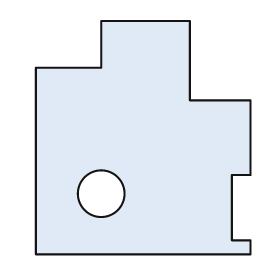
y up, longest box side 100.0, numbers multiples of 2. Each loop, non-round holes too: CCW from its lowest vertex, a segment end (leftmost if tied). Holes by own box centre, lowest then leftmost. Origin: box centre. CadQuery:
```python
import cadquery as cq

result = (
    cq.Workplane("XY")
    .moveTo(-46.0, -50.0)
    .lineTo(46.0, -50.0)
    .lineTo(46.0, -44.0)
    .lineTo(38.0, -44.0)
    .lineTo(38.0, -16.0)
    .lineTo(46.0, -16.0)
    .lineTo(46.0, 16.0)
    .lineTo(20.0, 16.0)
    .lineTo(20.0, 50.0)
    .lineTo(-18.0, 50.0)
    .lineTo(-18.0, 30.0)
    .lineTo(-46.0, 30.0)
    .close()
    .moveTo(-18.0, -24.0)
    .circle(10.0)
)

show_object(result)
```